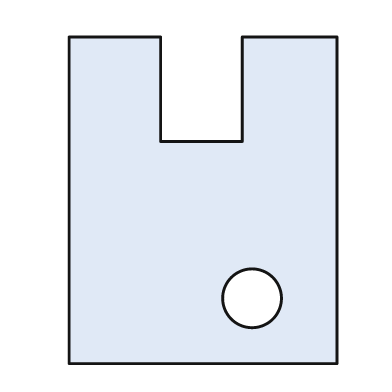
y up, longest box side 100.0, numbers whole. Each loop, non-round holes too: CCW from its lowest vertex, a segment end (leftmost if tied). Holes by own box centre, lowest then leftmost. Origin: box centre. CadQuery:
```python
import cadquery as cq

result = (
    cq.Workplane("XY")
    .moveTo(-41.0, -50.0)
    .lineTo(41.0, -50.0)
    .lineTo(41.0, 50.0)
    .lineTo(12.0, 50.0)
    .lineTo(12.0, 18.0)
    .lineTo(-13.0, 18.0)
    .lineTo(-13.0, 50.0)
    .lineTo(-41.0, 50.0)
    .close()
    .moveTo(15.0, -30.0)
    .circle(9.0)
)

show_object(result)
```